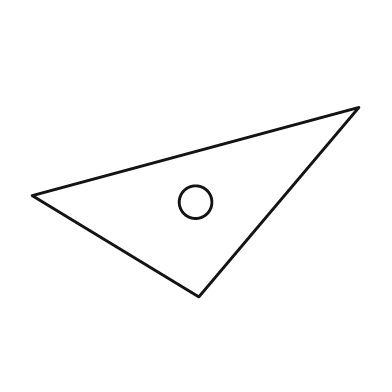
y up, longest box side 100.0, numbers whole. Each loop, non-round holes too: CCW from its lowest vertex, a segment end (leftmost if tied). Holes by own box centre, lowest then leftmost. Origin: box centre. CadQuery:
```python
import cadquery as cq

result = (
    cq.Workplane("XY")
    .moveTo(1.0, -29.0)
    .lineTo(50.0, 29.0)
    .lineTo(-50.0, 2.0)
    .close()
    .moveTo(0.0, 0.0)
    .circle(5.0)
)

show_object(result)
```